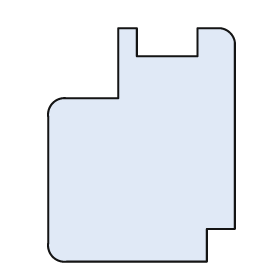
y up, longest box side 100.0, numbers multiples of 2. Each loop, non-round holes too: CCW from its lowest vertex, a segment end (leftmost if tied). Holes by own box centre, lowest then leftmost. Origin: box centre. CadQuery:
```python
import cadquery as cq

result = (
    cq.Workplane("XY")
    .moveTo(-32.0, -50.0)
    .lineTo(28.0, -50.0)
    .lineTo(28.0, -36.0)
    .lineTo(40.0, -36.0)
    .lineTo(40.0, 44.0)
    .threePointArc((38.0, 48.0), (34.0, 50.0))
    .lineTo(24.0, 50.0)
    .lineTo(24.0, 38.0)
    .lineTo(-2.0, 38.0)
    .lineTo(-2.0, 50.0)
    .lineTo(-10.0, 50.0)
    .lineTo(-10.0, 20.0)
    .lineTo(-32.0, 20.0)
    .threePointArc((-38.0, 18.0), (-40.0, 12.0))
    .lineTo(-40.0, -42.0)
    .threePointArc((-38.0, -48.0), (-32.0, -50.0))
    .close()
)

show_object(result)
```